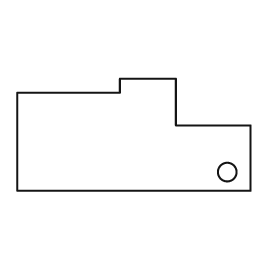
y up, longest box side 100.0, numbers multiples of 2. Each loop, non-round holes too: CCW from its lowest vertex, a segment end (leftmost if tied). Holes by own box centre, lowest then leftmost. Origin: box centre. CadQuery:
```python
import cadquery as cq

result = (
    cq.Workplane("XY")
    .moveTo(-50.0, -24.0)
    .lineTo(50.0, -24.0)
    .lineTo(50.0, 4.0)
    .lineTo(18.0, 4.0)
    .lineTo(18.0, 24.0)
    .lineTo(-6.0, 24.0)
    .lineTo(-6.0, 18.0)
    .lineTo(-50.0, 18.0)
    .close()
    .moveTo(40.0, -16.0)
    .circle(4.0)
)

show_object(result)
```